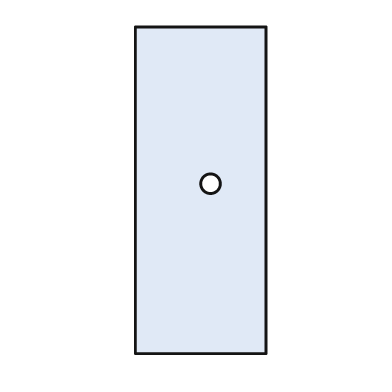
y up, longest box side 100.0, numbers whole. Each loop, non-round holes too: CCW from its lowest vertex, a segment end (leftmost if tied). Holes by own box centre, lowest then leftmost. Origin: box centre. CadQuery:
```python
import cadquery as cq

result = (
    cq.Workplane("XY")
    .moveTo(-20.0, -50.0)
    .lineTo(20.0, -50.0)
    .lineTo(20.0, 50.0)
    .lineTo(-20.0, 50.0)
    .close()
    .moveTo(3.0, 2.0)
    .circle(3.0)
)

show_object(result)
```